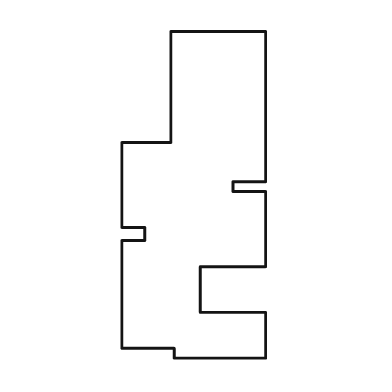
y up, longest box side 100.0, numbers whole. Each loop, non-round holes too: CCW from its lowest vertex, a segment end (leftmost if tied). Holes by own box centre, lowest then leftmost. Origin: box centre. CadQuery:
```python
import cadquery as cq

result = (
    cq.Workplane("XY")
    .moveTo(-6.0, -50.0)
    .lineTo(22.0, -50.0)
    .lineTo(22.0, -36.0)
    .lineTo(2.0, -36.0)
    .lineTo(2.0, -22.0)
    .lineTo(22.0, -22.0)
    .lineTo(22.0, 1.0)
    .lineTo(12.0, 1.0)
    .lineTo(12.0, 4.0)
    .lineTo(22.0, 4.0)
    .lineTo(22.0, 50.0)
    .lineTo(-7.0, 50.0)
    .lineTo(-7.0, 16.0)
    .lineTo(-22.0, 16.0)
    .lineTo(-22.0, -10.0)
    .lineTo(-15.0, -10.0)
    .lineTo(-15.0, -14.0)
    .lineTo(-22.0, -14.0)
    .lineTo(-22.0, -47.0)
    .lineTo(-6.0, -47.0)
    .close()
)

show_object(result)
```